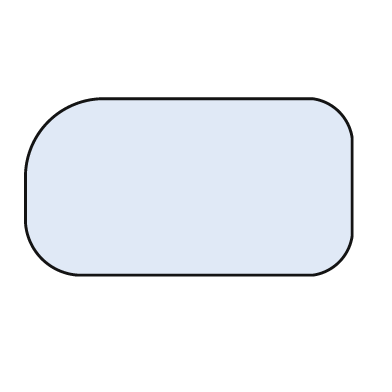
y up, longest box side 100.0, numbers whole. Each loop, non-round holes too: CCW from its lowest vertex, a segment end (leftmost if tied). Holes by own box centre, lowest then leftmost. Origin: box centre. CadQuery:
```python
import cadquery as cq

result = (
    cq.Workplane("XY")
    .moveTo(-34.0, -27.0)
    .lineTo(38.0, -27.0)
    .threePointArc((46.0, -23.0), (50.0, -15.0))
    .lineTo(50.0, 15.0)
    .threePointArc((46.0, 23.0), (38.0, 27.0))
    .lineTo(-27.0, 27.0)
    .threePointArc((-43.0, 20.0), (-50.0, 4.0))
    .lineTo(-50.0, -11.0)
    .threePointArc((-45.0, -22.0), (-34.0, -27.0))
    .close()
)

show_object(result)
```